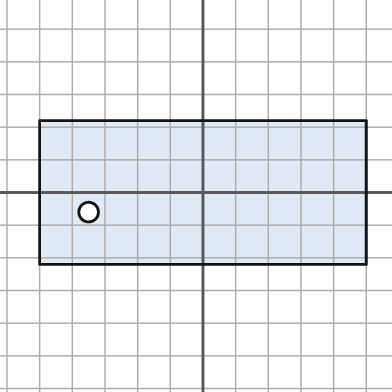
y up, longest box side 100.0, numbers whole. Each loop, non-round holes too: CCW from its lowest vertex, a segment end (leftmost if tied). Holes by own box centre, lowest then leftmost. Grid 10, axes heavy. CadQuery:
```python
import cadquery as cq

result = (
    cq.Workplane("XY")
    .moveTo(-50.0, -22.0)
    .lineTo(50.0, -22.0)
    .lineTo(50.0, 22.0)
    .lineTo(-50.0, 22.0)
    .close()
    .moveTo(-35.0, -6.0)
    .circle(3.0)
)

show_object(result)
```